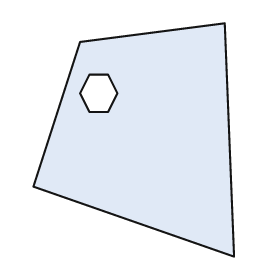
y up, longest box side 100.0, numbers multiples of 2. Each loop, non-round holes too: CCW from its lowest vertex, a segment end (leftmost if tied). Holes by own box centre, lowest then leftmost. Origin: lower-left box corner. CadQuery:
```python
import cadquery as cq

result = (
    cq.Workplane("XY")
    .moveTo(86.0, 0.0)
    .lineTo(82.0, 100.0)
    .lineTo(20.0, 92.0)
    .lineTo(0.0, 30.0)
    .close()
    .moveTo(24.0, 62.0)
    .lineTo(32.0, 62.0)
    .lineTo(36.0, 70.0)
    .lineTo(32.0, 78.0)
    .lineTo(24.0, 78.0)
    .lineTo(20.0, 70.0)
    .close()
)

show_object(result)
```